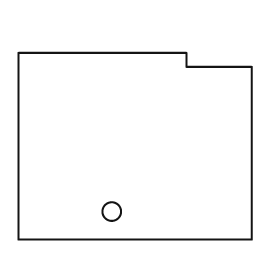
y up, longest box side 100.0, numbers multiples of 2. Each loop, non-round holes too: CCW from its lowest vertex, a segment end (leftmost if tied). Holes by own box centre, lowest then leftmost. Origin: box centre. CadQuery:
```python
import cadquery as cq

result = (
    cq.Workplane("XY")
    .moveTo(-50.0, -40.0)
    .lineTo(50.0, -40.0)
    .lineTo(50.0, 34.0)
    .lineTo(22.0, 34.0)
    .lineTo(22.0, 40.0)
    .lineTo(-50.0, 40.0)
    .close()
    .moveTo(-10.0, -28.0)
    .circle(4.0)
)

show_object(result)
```